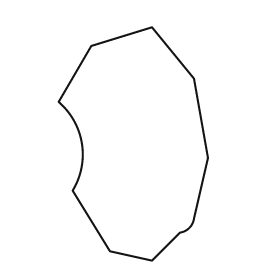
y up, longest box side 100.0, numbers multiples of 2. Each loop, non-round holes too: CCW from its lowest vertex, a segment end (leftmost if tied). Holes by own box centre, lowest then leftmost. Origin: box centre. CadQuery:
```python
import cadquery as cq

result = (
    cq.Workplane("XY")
    .moveTo(8.0, -50.0)
    .lineTo(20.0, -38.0)
    .threePointArc((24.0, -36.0), (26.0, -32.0))
    .lineTo(32.0, -6.0)
    .lineTo(26.0, 28.0)
    .lineTo(8.0, 50.0)
    .lineTo(-18.0, 42.0)
    .lineTo(-32.0, 18.0)
    .threePointArc((-22.0, 0.0), (-26.0, -20.0))
    .lineTo(-10.0, -46.0)
    .close()
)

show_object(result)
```